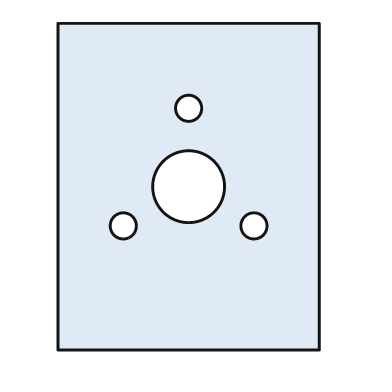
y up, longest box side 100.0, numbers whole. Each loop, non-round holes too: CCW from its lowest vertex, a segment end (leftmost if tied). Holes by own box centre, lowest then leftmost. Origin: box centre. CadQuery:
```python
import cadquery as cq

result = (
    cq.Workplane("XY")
    .moveTo(-40.0, -50.0)
    .lineTo(40.0, -50.0)
    .lineTo(40.0, 50.0)
    .lineTo(-40.0, 50.0)
    .close()
    .moveTo(-20.0, -12.0)
    .circle(4.0)
    .moveTo(20.0, -12.0)
    .circle(4.0)
    .moveTo(0.0, 0.0)
    .circle(11.0)
    .moveTo(0.0, 24.0)
    .circle(4.0)
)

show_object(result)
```